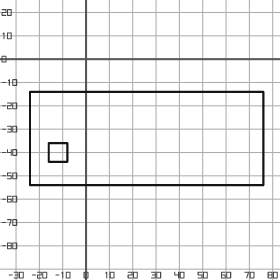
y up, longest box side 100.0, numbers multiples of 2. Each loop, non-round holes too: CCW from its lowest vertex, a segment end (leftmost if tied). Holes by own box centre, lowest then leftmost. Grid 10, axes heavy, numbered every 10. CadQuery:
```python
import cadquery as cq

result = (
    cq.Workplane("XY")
    .moveTo(-24.0, -54.0)
    .lineTo(76.0, -54.0)
    .lineTo(76.0, -14.0)
    .lineTo(-24.0, -14.0)
    .close()
    .moveTo(-16.0, -44.0)
    .lineTo(-8.0, -44.0)
    .lineTo(-8.0, -36.0)
    .lineTo(-16.0, -36.0)
    .close()
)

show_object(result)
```